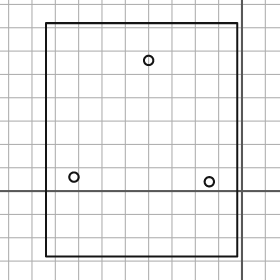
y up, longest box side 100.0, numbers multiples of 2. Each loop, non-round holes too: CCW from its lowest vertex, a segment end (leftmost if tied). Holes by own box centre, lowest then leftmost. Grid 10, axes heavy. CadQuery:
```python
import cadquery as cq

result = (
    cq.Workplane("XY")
    .moveTo(-84.0, -28.0)
    .lineTo(-2.0, -28.0)
    .lineTo(-2.0, 72.0)
    .lineTo(-84.0, 72.0)
    .close()
    .moveTo(-14.0, 4.0)
    .circle(2.0)
    .moveTo(-72.0, 6.0)
    .circle(2.0)
    .moveTo(-40.0, 56.0)
    .circle(2.0)
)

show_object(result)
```